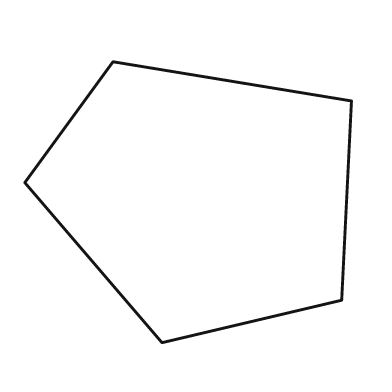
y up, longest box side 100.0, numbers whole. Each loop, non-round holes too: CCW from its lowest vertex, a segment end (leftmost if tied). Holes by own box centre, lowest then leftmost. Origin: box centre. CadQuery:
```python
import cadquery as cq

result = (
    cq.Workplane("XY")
    .moveTo(-8.0, -43.0)
    .lineTo(47.0, -30.0)
    .lineTo(50.0, 31.0)
    .lineTo(-23.0, 43.0)
    .lineTo(-50.0, 6.0)
    .close()
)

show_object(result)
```